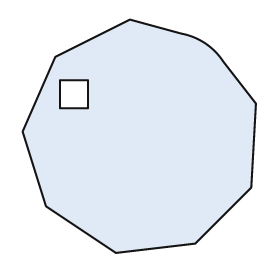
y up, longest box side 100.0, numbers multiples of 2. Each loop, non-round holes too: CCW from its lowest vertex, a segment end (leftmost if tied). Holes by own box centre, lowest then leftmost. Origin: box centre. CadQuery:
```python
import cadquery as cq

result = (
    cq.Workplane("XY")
    .moveTo(-10.0, -50.0)
    .lineTo(24.0, -46.0)
    .lineTo(48.0, -22.0)
    .lineTo(50.0, 14.0)
    .lineTo(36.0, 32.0)
    .threePointArc((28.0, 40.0), (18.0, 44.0))
    .lineTo(-4.0, 50.0)
    .lineTo(-36.0, 34.0)
    .lineTo(-50.0, 2.0)
    .lineTo(-40.0, -30.0)
    .close()
    .moveTo(-34.0, 12.0)
    .lineTo(-22.0, 12.0)
    .lineTo(-22.0, 24.0)
    .lineTo(-34.0, 24.0)
    .close()
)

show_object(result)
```